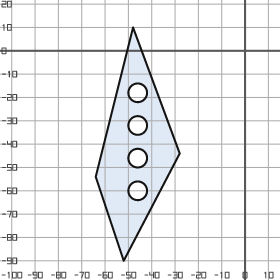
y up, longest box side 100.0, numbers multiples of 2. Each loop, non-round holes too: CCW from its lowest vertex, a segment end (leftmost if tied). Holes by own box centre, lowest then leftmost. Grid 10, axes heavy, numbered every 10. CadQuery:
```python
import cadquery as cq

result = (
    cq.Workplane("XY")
    .moveTo(-52.0, -90.0)
    .lineTo(-28.0, -44.0)
    .lineTo(-48.0, 10.0)
    .lineTo(-64.0, -54.0)
    .close()
    .moveTo(-46.0, -60.0)
    .circle(4.0)
    .moveTo(-46.0, -46.0)
    .circle(4.0)
    .moveTo(-46.0, -32.0)
    .circle(4.0)
    .moveTo(-46.0, -18.0)
    .circle(4.0)
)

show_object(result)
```